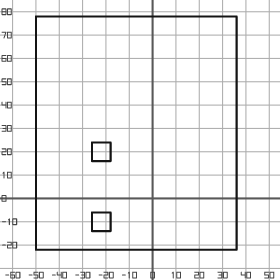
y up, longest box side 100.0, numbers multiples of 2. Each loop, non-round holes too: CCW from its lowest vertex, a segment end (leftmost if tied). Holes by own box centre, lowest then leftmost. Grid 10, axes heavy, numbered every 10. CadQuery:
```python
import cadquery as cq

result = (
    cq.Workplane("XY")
    .moveTo(-50.0, -22.0)
    .lineTo(36.0, -22.0)
    .lineTo(36.0, 78.0)
    .lineTo(-50.0, 78.0)
    .close()
    .moveTo(-26.0, -14.0)
    .lineTo(-18.0, -14.0)
    .lineTo(-18.0, -6.0)
    .lineTo(-26.0, -6.0)
    .close()
    .moveTo(-26.0, 16.0)
    .lineTo(-18.0, 16.0)
    .lineTo(-18.0, 24.0)
    .lineTo(-26.0, 24.0)
    .close()
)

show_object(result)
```